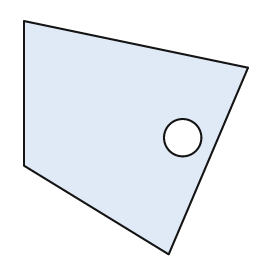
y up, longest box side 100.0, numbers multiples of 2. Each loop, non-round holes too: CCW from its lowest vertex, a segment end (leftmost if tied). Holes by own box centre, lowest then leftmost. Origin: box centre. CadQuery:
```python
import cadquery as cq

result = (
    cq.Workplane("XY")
    .moveTo(14.0, -50.0)
    .lineTo(48.0, 30.0)
    .lineTo(-48.0, 50.0)
    .lineTo(-48.0, -12.0)
    .close()
    .moveTo(20.0, 0.0)
    .circle(8.0)
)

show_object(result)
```